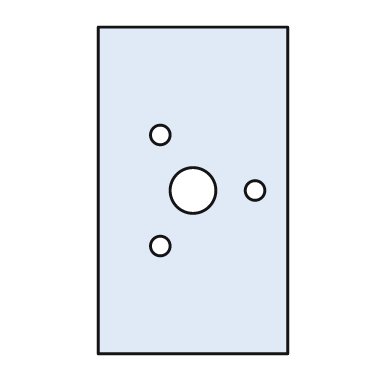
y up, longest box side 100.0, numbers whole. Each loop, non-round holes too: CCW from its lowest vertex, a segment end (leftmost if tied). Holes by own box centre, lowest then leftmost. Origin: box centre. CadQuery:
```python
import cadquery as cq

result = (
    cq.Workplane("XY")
    .moveTo(-29.0, -50.0)
    .lineTo(29.0, -50.0)
    .lineTo(29.0, 50.0)
    .lineTo(-29.0, 50.0)
    .close()
    .moveTo(-10.0, -17.0)
    .circle(3.0)
    .moveTo(0.0, 0.0)
    .circle(7.0)
    .moveTo(19.0, 0.0)
    .circle(3.0)
    .moveTo(-10.0, 17.0)
    .circle(3.0)
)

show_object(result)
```